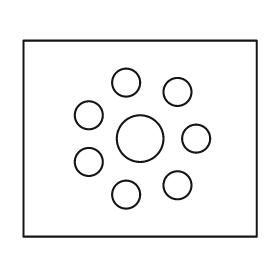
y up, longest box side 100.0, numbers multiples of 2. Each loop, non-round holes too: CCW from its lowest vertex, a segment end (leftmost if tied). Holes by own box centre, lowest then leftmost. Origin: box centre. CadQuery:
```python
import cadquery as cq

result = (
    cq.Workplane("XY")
    .moveTo(-50.0, -42.0)
    .lineTo(50.0, -42.0)
    .lineTo(50.0, 42.0)
    .lineTo(-50.0, 42.0)
    .close()
    .moveTo(-6.0, -24.0)
    .circle(6.0)
    .moveTo(16.0, -20.0)
    .circle(6.0)
    .moveTo(-22.0, -10.0)
    .circle(6.0)
    .moveTo(0.0, 0.0)
    .circle(10.0)
    .moveTo(24.0, 0.0)
    .circle(6.0)
    .moveTo(-22.0, 10.0)
    .circle(6.0)
    .moveTo(16.0, 20.0)
    .circle(6.0)
    .moveTo(-6.0, 24.0)
    .circle(6.0)
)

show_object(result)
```